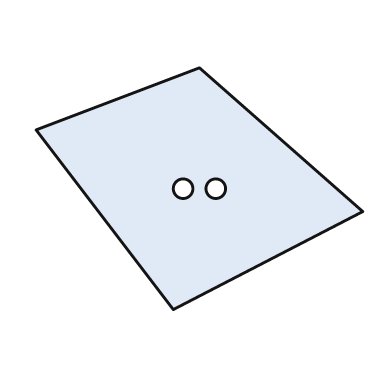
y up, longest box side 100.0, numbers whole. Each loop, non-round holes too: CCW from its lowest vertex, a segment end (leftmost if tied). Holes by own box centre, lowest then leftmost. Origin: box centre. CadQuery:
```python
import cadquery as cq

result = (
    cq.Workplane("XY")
    .moveTo(-8.0, -37.0)
    .lineTo(50.0, -7.0)
    .lineTo(0.0, 37.0)
    .lineTo(-50.0, 18.0)
    .close()
    .moveTo(-5.0, 0.0)
    .circle(3.0)
    .moveTo(5.0, 0.0)
    .circle(3.0)
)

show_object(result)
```